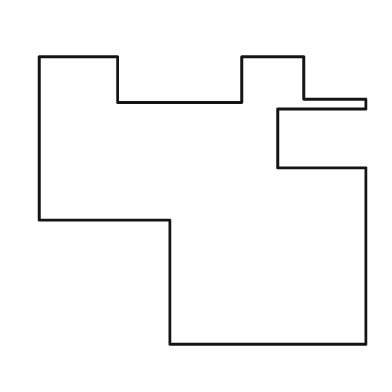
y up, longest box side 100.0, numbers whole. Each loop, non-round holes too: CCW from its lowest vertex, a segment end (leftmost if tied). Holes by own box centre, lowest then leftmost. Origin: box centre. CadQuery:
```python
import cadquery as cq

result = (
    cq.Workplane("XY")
    .moveTo(-10.0, -44.0)
    .lineTo(50.0, -44.0)
    .lineTo(50.0, 10.0)
    .lineTo(23.0, 10.0)
    .lineTo(23.0, 28.0)
    .lineTo(50.0, 28.0)
    .lineTo(50.0, 31.0)
    .lineTo(31.0, 31.0)
    .lineTo(31.0, 44.0)
    .lineTo(12.0, 44.0)
    .lineTo(12.0, 30.0)
    .lineTo(-26.0, 30.0)
    .lineTo(-26.0, 44.0)
    .lineTo(-50.0, 44.0)
    .lineTo(-50.0, -6.0)
    .lineTo(-10.0, -6.0)
    .close()
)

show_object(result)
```